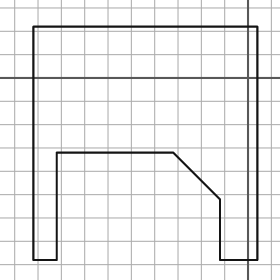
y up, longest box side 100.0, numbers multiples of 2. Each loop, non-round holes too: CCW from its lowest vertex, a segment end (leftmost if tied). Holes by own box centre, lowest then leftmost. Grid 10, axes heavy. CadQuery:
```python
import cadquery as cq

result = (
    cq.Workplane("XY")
    .moveTo(-92.0, -78.0)
    .lineTo(-82.0, -78.0)
    .lineTo(-82.0, -32.0)
    .lineTo(-32.0, -32.0)
    .lineTo(-12.0, -52.0)
    .lineTo(-12.0, -78.0)
    .lineTo(4.0, -78.0)
    .lineTo(4.0, 22.0)
    .lineTo(-92.0, 22.0)
    .close()
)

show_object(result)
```